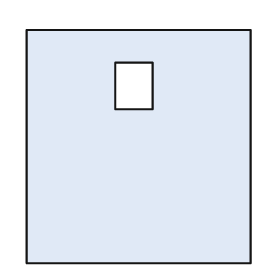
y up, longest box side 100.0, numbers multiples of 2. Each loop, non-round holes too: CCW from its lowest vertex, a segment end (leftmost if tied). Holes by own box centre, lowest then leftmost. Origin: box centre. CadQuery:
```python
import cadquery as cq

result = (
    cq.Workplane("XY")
    .moveTo(-48.0, -50.0)
    .lineTo(48.0, -50.0)
    .lineTo(48.0, 50.0)
    .lineTo(-48.0, 50.0)
    .close()
    .moveTo(-10.0, 16.0)
    .lineTo(6.0, 16.0)
    .lineTo(6.0, 36.0)
    .lineTo(-10.0, 36.0)
    .close()
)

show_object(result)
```